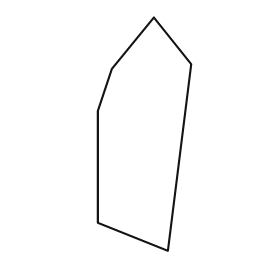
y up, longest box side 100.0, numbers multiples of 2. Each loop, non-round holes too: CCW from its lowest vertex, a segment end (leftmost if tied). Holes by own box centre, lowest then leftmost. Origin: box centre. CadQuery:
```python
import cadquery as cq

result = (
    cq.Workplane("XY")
    .moveTo(10.0, -50.0)
    .lineTo(20.0, 30.0)
    .lineTo(4.0, 50.0)
    .lineTo(-14.0, 28.0)
    .lineTo(-20.0, 10.0)
    .lineTo(-20.0, -38.0)
    .close()
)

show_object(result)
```